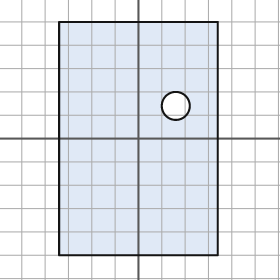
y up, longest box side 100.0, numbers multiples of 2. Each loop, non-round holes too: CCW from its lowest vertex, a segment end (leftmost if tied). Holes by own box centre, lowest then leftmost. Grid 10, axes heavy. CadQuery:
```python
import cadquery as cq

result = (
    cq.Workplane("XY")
    .moveTo(-34.0, -50.0)
    .lineTo(34.0, -50.0)
    .lineTo(34.0, 50.0)
    .lineTo(-34.0, 50.0)
    .close()
    .moveTo(16.0, 14.0)
    .circle(6.0)
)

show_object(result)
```